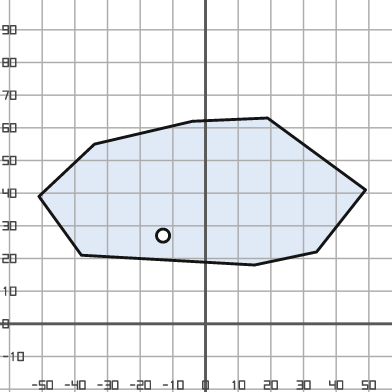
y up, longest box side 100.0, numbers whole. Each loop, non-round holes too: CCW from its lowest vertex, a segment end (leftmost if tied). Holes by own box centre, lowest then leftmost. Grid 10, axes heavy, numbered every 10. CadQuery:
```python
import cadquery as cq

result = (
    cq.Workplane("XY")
    .moveTo(15.0, 18.0)
    .lineTo(34.0, 22.0)
    .lineTo(49.0, 41.0)
    .lineTo(19.0, 63.0)
    .lineTo(-4.0, 62.0)
    .lineTo(-34.0, 55.0)
    .lineTo(-51.0, 39.0)
    .lineTo(-38.0, 21.0)
    .close()
    .moveTo(-13.0, 27.0)
    .circle(2.0)
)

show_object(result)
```